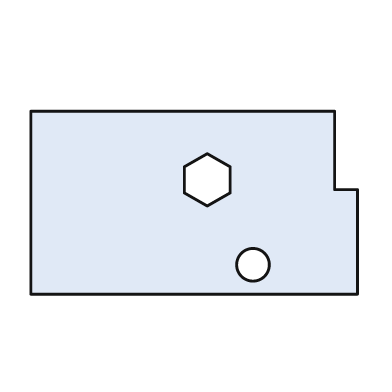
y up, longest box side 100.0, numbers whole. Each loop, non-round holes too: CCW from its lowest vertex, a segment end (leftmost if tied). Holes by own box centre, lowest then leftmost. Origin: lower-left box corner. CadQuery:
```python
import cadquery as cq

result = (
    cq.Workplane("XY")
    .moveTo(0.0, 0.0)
    .lineTo(100.0, 0.0)
    .lineTo(100.0, 32.0)
    .lineTo(93.0, 32.0)
    .lineTo(93.0, 56.0)
    .lineTo(0.0, 56.0)
    .close()
    .moveTo(68.0, 9.0)
    .circle(5.0)
    .moveTo(54.0, 27.0)
    .lineTo(61.0, 31.0)
    .lineTo(61.0, 39.0)
    .lineTo(54.0, 43.0)
    .lineTo(47.0, 39.0)
    .lineTo(47.0, 31.0)
    .close()
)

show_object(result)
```